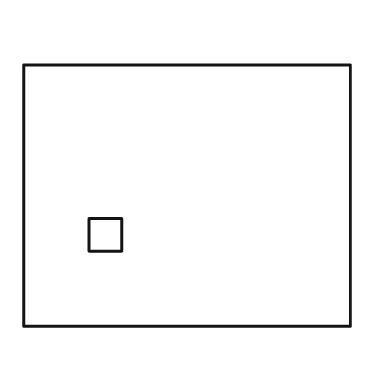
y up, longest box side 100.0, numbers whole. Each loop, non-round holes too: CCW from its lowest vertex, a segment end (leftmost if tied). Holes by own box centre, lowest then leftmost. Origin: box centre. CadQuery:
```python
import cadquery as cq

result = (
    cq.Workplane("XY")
    .moveTo(-50.0, -40.0)
    .lineTo(50.0, -40.0)
    .lineTo(50.0, 40.0)
    .lineTo(-50.0, 40.0)
    .close()
    .moveTo(-30.0, -17.0)
    .lineTo(-20.0, -17.0)
    .lineTo(-20.0, -7.0)
    .lineTo(-30.0, -7.0)
    .close()
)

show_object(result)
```